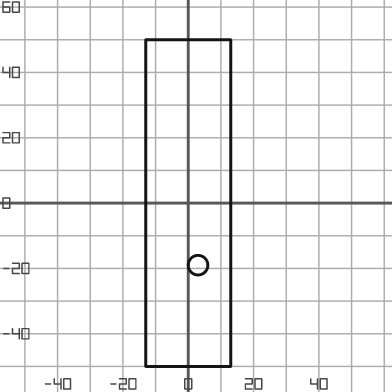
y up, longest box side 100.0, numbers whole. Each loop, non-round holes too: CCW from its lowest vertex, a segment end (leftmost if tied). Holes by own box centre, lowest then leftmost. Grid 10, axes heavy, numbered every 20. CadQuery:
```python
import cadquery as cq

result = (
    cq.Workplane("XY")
    .moveTo(-13.0, -50.0)
    .lineTo(13.0, -50.0)
    .lineTo(13.0, 50.0)
    .lineTo(-13.0, 50.0)
    .close()
    .moveTo(3.0, -19.0)
    .circle(3.0)
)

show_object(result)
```